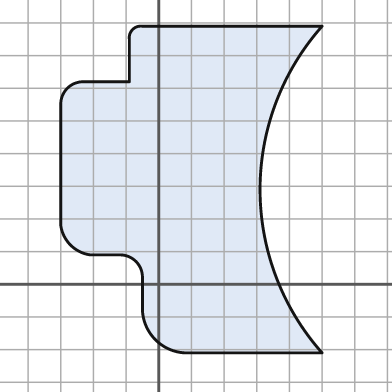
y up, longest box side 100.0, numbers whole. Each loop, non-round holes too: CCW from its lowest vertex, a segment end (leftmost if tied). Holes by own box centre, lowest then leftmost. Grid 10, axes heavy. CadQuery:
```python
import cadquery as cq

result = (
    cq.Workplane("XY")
    .moveTo(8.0, -21.0)
    .lineTo(50.0, -21.0)
    .threePointArc((31.0, 29.0), (50.0, 79.0))
    .lineTo(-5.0, 79.0)
    .threePointArc((-8.0, 78.0), (-9.0, 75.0))
    .lineTo(-9.0, 62.0)
    .lineTo(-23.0, 62.0)
    .threePointArc((-28.0, 60.0), (-30.0, 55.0))
    .lineTo(-30.0, 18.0)
    .threePointArc((-27.0, 12.0), (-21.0, 9.0))
    .lineTo(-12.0, 9.0)
    .threePointArc((-7.0, 7.0), (-5.0, 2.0))
    .lineTo(-5.0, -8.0)
    .threePointArc((-1.0, -17.0), (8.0, -21.0))
    .close()
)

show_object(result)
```